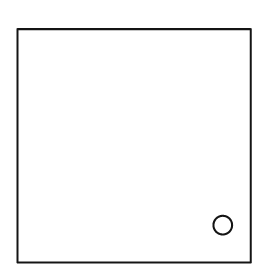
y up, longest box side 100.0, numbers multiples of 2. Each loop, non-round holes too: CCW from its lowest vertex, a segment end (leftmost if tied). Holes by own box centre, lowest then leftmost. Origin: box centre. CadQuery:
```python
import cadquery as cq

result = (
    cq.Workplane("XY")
    .moveTo(-50.0, -50.0)
    .lineTo(50.0, -50.0)
    .lineTo(50.0, 50.0)
    .lineTo(-50.0, 50.0)
    .close()
    .moveTo(38.0, -34.0)
    .circle(4.0)
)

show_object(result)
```